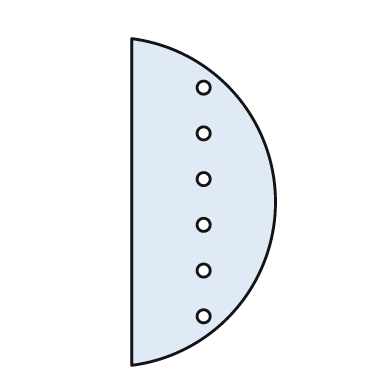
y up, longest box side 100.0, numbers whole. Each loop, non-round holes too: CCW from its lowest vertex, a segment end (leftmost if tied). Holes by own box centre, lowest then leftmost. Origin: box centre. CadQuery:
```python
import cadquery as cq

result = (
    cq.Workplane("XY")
    .moveTo(-22.0, -50.0)
    .threePointArc((22.0, 0.0), (-22.0, 50.0))
    .close()
    .moveTo(0.0, -35.0)
    .circle(2.0)
    .moveTo(0.0, -21.0)
    .circle(2.0)
    .moveTo(0.0, -7.0)
    .circle(2.0)
    .moveTo(0.0, 7.0)
    .circle(2.0)
    .moveTo(0.0, 21.0)
    .circle(2.0)
    .moveTo(0.0, 35.0)
    .circle(2.0)
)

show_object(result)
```